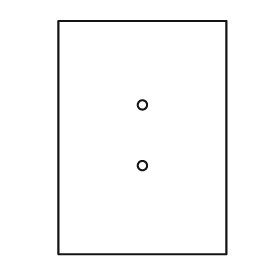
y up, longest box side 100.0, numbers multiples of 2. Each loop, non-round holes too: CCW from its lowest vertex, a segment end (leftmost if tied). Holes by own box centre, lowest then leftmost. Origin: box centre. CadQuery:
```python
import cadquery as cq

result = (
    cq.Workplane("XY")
    .moveTo(-36.0, -50.0)
    .lineTo(36.0, -50.0)
    .lineTo(36.0, 50.0)
    .lineTo(-36.0, 50.0)
    .close()
    .moveTo(0.0, -12.0)
    .circle(2.0)
    .moveTo(0.0, 14.0)
    .circle(2.0)
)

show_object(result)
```